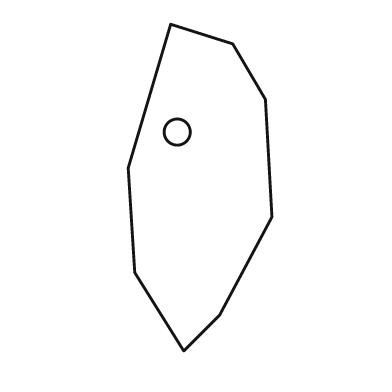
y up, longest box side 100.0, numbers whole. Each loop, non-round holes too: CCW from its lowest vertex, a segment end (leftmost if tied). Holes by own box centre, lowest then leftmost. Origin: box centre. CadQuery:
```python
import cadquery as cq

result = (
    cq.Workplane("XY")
    .moveTo(-5.0, -50.0)
    .lineTo(6.0, -39.0)
    .lineTo(22.0, -9.0)
    .lineTo(20.0, 27.0)
    .lineTo(10.0, 44.0)
    .lineTo(-9.0, 50.0)
    .lineTo(-22.0, 6.0)
    .lineTo(-20.0, -26.0)
    .close()
    .moveTo(-7.0, 17.0)
    .circle(4.0)
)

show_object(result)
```